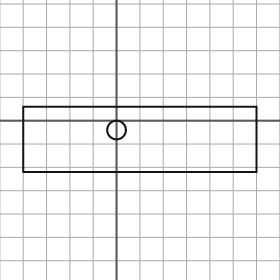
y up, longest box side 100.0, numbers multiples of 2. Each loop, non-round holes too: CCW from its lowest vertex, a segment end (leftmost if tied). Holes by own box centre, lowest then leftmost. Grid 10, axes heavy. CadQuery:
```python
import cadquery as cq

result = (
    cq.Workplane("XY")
    .moveTo(-40.0, -22.0)
    .lineTo(60.0, -22.0)
    .lineTo(60.0, 6.0)
    .lineTo(-40.0, 6.0)
    .close()
    .moveTo(0.0, -4.0)
    .circle(4.0)
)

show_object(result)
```